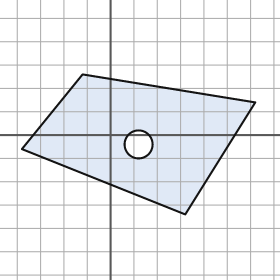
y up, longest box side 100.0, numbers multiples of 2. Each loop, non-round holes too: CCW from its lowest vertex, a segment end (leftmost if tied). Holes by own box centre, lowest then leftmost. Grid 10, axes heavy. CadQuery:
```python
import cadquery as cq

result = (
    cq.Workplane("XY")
    .moveTo(32.0, -34.0)
    .lineTo(62.0, 14.0)
    .lineTo(-12.0, 26.0)
    .lineTo(-38.0, -6.0)
    .close()
    .moveTo(12.0, -4.0)
    .circle(6.0)
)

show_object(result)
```